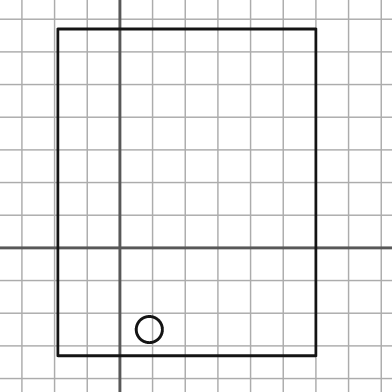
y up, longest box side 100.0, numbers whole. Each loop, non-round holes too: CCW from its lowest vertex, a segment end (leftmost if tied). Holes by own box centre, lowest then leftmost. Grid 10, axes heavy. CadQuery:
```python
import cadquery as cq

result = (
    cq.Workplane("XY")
    .moveTo(-19.0, -33.0)
    .lineTo(60.0, -33.0)
    .lineTo(60.0, 67.0)
    .lineTo(-19.0, 67.0)
    .close()
    .moveTo(9.0, -25.0)
    .circle(4.0)
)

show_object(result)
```